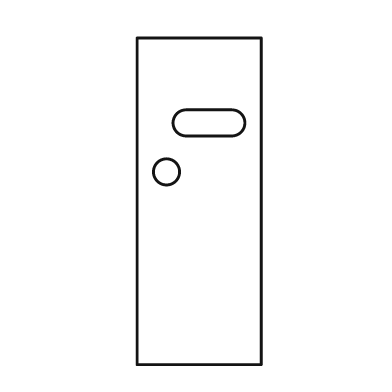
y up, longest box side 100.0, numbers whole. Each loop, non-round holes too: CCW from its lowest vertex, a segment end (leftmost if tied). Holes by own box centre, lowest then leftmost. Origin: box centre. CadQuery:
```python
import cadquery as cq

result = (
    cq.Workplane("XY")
    .moveTo(-19.0, -50.0)
    .lineTo(19.0, -50.0)
    .lineTo(19.0, 50.0)
    .lineTo(-19.0, 50.0)
    .close()
    .moveTo(-10.0, 9.0)
    .circle(4.0)
    .moveTo(-4.0, 20.0)
    .lineTo(10.0, 20.0)
    .threePointArc((14.0, 24.0), (10.0, 28.0))
    .lineTo(-4.0, 28.0)
    .threePointArc((-8.0, 24.0), (-4.0, 20.0))
    .close()
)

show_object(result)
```